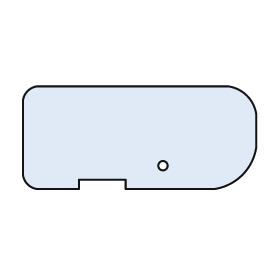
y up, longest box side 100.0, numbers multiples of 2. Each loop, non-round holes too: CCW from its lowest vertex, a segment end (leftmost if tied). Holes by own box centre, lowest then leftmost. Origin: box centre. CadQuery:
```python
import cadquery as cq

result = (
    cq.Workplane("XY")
    .moveTo(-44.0, -22.0)
    .lineTo(-26.0, -22.0)
    .lineTo(-26.0, -18.0)
    .lineTo(-6.0, -18.0)
    .lineTo(-6.0, -22.0)
    .lineTo(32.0, -22.0)
    .threePointArc((44.0, -16.0), (50.0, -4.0))
    .lineTo(50.0, 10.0)
    .threePointArc((46.0, 18.0), (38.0, 22.0))
    .lineTo(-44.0, 22.0)
    .threePointArc((-48.0, 20.0), (-50.0, 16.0))
    .lineTo(-50.0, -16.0)
    .threePointArc((-48.0, -20.0), (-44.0, -22.0))
    .close()
    .moveTo(10.0, -12.0)
    .circle(2.0)
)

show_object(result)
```